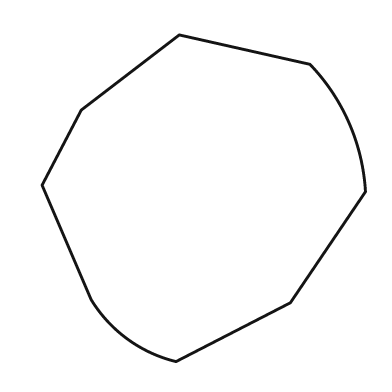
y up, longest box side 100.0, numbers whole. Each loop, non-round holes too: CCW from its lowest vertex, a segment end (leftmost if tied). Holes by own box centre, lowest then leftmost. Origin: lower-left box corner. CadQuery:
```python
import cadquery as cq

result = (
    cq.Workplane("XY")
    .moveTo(41.0, 0.0)
    .lineTo(76.0, 18.0)
    .lineTo(99.0, 52.0)
    .threePointArc((94.0, 73.0), (82.0, 91.0))
    .lineTo(42.0, 100.0)
    .lineTo(12.0, 77.0)
    .lineTo(0.0, 54.0)
    .lineTo(15.0, 19.0)
    .threePointArc((26.0, 7.0), (41.0, 0.0))
    .close()
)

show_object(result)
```